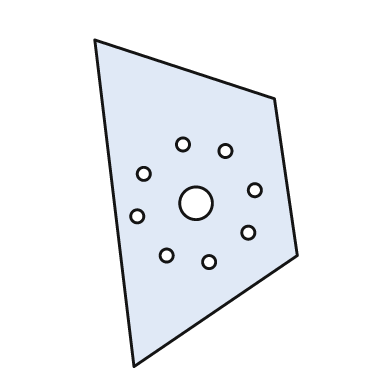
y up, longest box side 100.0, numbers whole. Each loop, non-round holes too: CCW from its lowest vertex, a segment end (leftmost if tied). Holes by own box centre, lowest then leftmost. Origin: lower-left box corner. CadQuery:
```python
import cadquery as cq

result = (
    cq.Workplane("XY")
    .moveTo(12.0, 0.0)
    .lineTo(62.0, 34.0)
    .lineTo(55.0, 82.0)
    .lineTo(0.0, 100.0)
    .close()
    .moveTo(35.0, 32.0)
    .circle(2.0)
    .moveTo(22.0, 34.0)
    .circle(2.0)
    .moveTo(47.0, 41.0)
    .circle(2.0)
    .moveTo(13.0, 46.0)
    .circle(2.0)
    .moveTo(31.0, 50.0)
    .circle(5.0)
    .moveTo(49.0, 54.0)
    .circle(2.0)
    .moveTo(15.0, 59.0)
    .circle(2.0)
    .moveTo(40.0, 66.0)
    .circle(2.0)
    .moveTo(27.0, 68.0)
    .circle(2.0)
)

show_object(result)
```